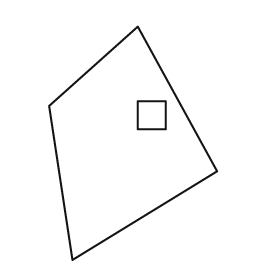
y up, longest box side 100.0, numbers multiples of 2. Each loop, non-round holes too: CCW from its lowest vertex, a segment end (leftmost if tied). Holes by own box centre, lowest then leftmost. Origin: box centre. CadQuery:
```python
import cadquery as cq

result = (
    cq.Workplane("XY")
    .moveTo(-26.0, -50.0)
    .lineTo(36.0, -12.0)
    .lineTo(2.0, 50.0)
    .lineTo(-36.0, 16.0)
    .close()
    .moveTo(2.0, 6.0)
    .lineTo(14.0, 6.0)
    .lineTo(14.0, 18.0)
    .lineTo(2.0, 18.0)
    .close()
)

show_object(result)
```